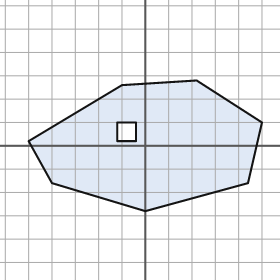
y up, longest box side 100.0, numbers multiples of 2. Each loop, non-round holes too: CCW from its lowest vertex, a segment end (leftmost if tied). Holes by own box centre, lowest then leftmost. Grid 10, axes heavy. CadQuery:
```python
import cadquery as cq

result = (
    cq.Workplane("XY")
    .moveTo(0.0, -28.0)
    .lineTo(44.0, -16.0)
    .lineTo(50.0, 10.0)
    .lineTo(22.0, 28.0)
    .lineTo(-10.0, 26.0)
    .lineTo(-50.0, 2.0)
    .lineTo(-40.0, -16.0)
    .close()
    .moveTo(-12.0, 2.0)
    .lineTo(-4.0, 2.0)
    .lineTo(-4.0, 10.0)
    .lineTo(-12.0, 10.0)
    .close()
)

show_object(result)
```